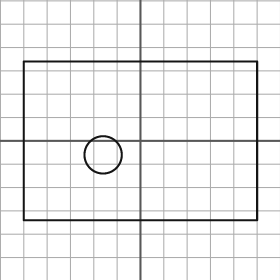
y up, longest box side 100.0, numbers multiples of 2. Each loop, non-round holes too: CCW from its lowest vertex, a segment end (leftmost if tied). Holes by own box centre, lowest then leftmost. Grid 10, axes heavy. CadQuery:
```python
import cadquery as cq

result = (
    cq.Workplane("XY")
    .moveTo(-50.0, -34.0)
    .lineTo(50.0, -34.0)
    .lineTo(50.0, 34.0)
    .lineTo(-50.0, 34.0)
    .close()
    .moveTo(-16.0, -6.0)
    .circle(8.0)
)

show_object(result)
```